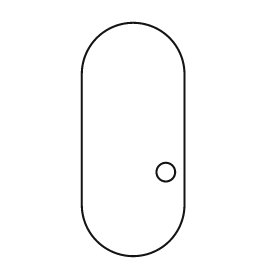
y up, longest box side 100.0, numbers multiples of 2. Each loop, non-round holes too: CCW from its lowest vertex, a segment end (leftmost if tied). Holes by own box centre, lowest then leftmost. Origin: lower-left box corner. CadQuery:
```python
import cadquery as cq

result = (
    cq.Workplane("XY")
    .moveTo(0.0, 22.0)
    .threePointArc((22.0, 0.0), (44.0, 22.0))
    .lineTo(44.0, 78.0)
    .threePointArc((22.0, 100.0), (0.0, 78.0))
    .close()
    .moveTo(36.0, 36.0)
    .circle(4.0)
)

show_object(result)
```